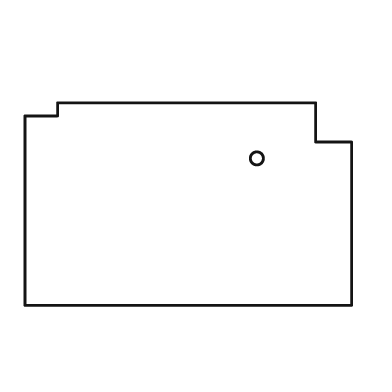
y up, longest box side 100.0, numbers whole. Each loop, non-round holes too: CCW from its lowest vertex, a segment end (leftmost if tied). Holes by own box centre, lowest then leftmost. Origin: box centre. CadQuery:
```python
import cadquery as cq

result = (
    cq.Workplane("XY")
    .moveTo(-50.0, -31.0)
    .lineTo(50.0, -31.0)
    .lineTo(50.0, 19.0)
    .lineTo(39.0, 19.0)
    .lineTo(39.0, 31.0)
    .lineTo(-40.0, 31.0)
    .lineTo(-40.0, 27.0)
    .lineTo(-50.0, 27.0)
    .close()
    .moveTo(21.0, 14.0)
    .circle(2.0)
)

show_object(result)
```